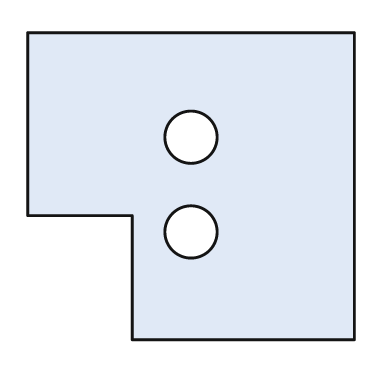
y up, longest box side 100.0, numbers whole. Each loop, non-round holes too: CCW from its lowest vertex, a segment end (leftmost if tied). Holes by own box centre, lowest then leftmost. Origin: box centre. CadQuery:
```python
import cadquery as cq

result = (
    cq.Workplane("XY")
    .moveTo(-18.0, -47.0)
    .lineTo(50.0, -47.0)
    .lineTo(50.0, 47.0)
    .lineTo(-50.0, 47.0)
    .lineTo(-50.0, -9.0)
    .lineTo(-18.0, -9.0)
    .close()
    .moveTo(0.0, -14.0)
    .circle(8.0)
    .moveTo(0.0, 15.0)
    .circle(8.0)
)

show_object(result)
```